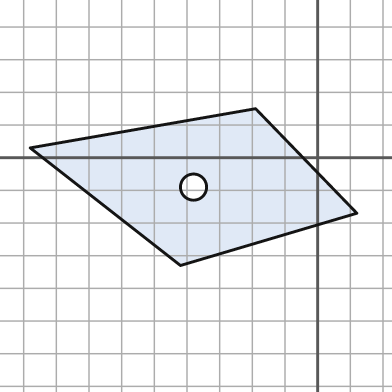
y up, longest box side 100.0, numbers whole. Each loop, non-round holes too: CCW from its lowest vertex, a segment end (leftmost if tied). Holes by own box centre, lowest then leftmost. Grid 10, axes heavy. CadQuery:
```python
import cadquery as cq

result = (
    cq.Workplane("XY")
    .moveTo(-42.0, -33.0)
    .lineTo(12.0, -17.0)
    .lineTo(-19.0, 15.0)
    .lineTo(-88.0, 3.0)
    .close()
    .moveTo(-38.0, -9.0)
    .circle(4.0)
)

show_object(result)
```